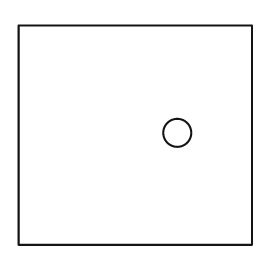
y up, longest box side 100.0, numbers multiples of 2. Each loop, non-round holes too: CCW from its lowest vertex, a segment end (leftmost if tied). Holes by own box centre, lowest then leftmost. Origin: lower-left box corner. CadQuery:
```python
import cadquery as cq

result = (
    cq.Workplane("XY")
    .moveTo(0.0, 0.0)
    .lineTo(100.0, 0.0)
    .lineTo(100.0, 94.0)
    .lineTo(0.0, 94.0)
    .close()
    .moveTo(68.0, 48.0)
    .circle(6.0)
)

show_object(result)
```